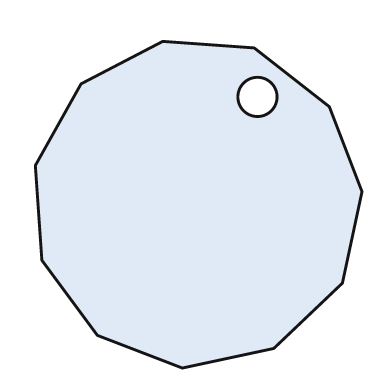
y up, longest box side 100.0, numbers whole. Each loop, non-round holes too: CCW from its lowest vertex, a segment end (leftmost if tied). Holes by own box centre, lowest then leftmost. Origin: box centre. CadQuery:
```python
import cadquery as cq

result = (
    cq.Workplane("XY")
    .moveTo(-5.0, -50.0)
    .lineTo(23.0, -44.0)
    .lineTo(44.0, -24.0)
    .lineTo(50.0, 4.0)
    .lineTo(40.0, 30.0)
    .lineTo(17.0, 48.0)
    .lineTo(-11.0, 50.0)
    .lineTo(-36.0, 37.0)
    .lineTo(-50.0, 12.0)
    .lineTo(-48.0, -17.0)
    .lineTo(-31.0, -40.0)
    .close()
    .moveTo(18.0, 33.0)
    .circle(6.0)
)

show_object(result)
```